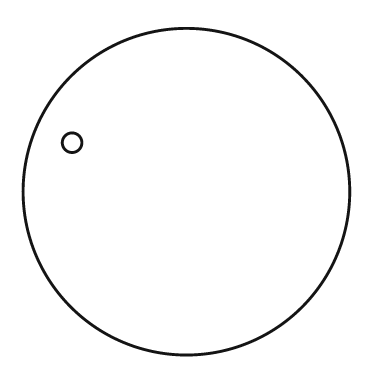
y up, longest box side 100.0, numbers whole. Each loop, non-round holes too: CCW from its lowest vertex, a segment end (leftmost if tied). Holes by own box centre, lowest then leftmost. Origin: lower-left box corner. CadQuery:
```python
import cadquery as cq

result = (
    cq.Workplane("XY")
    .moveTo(50.0, 50.0)
    .circle(50.0)
    .moveTo(15.0, 65.0)
    .circle(3.0)
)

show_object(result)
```